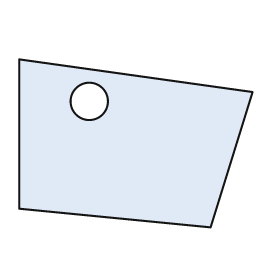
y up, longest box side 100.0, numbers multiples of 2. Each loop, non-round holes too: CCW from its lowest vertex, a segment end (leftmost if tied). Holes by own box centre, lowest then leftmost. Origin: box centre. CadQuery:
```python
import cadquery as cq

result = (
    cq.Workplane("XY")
    .moveTo(32.0, -36.0)
    .lineTo(50.0, 22.0)
    .lineTo(-50.0, 36.0)
    .lineTo(-50.0, -28.0)
    .close()
    .moveTo(-20.0, 18.0)
    .circle(8.0)
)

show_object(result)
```